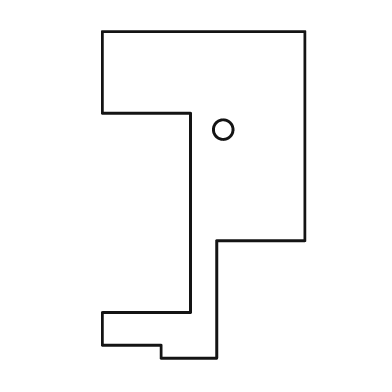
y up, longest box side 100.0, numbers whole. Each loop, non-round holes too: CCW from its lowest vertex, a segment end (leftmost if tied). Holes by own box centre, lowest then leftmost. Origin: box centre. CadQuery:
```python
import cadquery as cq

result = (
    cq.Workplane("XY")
    .moveTo(-13.0, -50.0)
    .lineTo(4.0, -50.0)
    .lineTo(4.0, -14.0)
    .lineTo(31.0, -14.0)
    .lineTo(31.0, 50.0)
    .lineTo(-31.0, 50.0)
    .lineTo(-31.0, 25.0)
    .lineTo(-4.0, 25.0)
    .lineTo(-4.0, -36.0)
    .lineTo(-31.0, -36.0)
    .lineTo(-31.0, -46.0)
    .lineTo(-13.0, -46.0)
    .close()
    .moveTo(6.0, 20.0)
    .circle(3.0)
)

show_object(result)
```